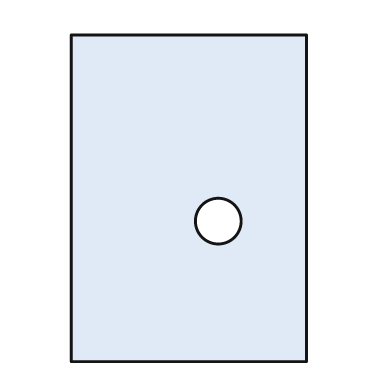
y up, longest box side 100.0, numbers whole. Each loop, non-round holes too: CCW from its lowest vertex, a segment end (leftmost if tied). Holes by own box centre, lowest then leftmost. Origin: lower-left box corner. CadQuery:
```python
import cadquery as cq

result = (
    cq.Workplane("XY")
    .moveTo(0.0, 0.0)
    .lineTo(72.0, 0.0)
    .lineTo(72.0, 100.0)
    .lineTo(0.0, 100.0)
    .close()
    .moveTo(45.0, 43.0)
    .circle(7.0)
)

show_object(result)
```